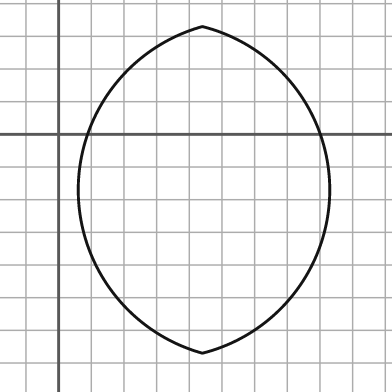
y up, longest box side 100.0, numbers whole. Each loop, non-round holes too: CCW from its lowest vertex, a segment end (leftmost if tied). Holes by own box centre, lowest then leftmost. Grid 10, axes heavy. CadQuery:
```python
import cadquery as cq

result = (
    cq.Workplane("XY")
    .moveTo(44.0, -67.0)
    .threePointArc((83.0, -17.0), (44.0, 33.0))
    .threePointArc((6.0, -17.0), (44.0, -67.0))
    .close()
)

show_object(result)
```